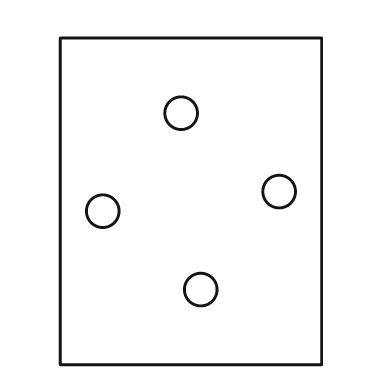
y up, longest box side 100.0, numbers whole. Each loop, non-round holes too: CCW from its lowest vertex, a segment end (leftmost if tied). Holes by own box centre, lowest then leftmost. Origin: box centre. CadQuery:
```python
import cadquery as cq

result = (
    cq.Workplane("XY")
    .moveTo(-40.0, -50.0)
    .lineTo(40.0, -50.0)
    .lineTo(40.0, 50.0)
    .lineTo(-40.0, 50.0)
    .close()
    .moveTo(3.0, -27.0)
    .circle(5.0)
    .moveTo(-27.0, -3.0)
    .circle(5.0)
    .moveTo(27.0, 3.0)
    .circle(5.0)
    .moveTo(-3.0, 27.0)
    .circle(5.0)
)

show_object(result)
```